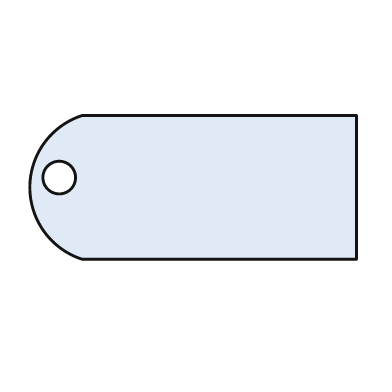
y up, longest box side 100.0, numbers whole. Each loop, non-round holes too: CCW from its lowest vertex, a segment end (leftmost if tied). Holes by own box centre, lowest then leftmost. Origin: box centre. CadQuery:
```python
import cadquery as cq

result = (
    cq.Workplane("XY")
    .moveTo(-34.0, -22.0)
    .lineTo(50.0, -22.0)
    .lineTo(50.0, 22.0)
    .lineTo(-34.0, 22.0)
    .threePointArc((-50.0, 0.0), (-34.0, -22.0))
    .close()
    .moveTo(-41.0, 3.0)
    .circle(5.0)
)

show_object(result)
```